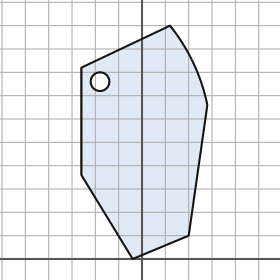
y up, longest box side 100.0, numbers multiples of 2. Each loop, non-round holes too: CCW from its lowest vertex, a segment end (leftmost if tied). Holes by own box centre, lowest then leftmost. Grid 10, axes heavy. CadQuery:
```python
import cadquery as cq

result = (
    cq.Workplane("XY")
    .moveTo(-4.0, 0.0)
    .lineTo(20.0, 10.0)
    .lineTo(28.0, 66.0)
    .threePointArc((22.0, 84.0), (12.0, 100.0))
    .lineTo(-26.0, 82.0)
    .lineTo(-26.0, 36.0)
    .close()
    .moveTo(-18.0, 76.0)
    .circle(4.0)
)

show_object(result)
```